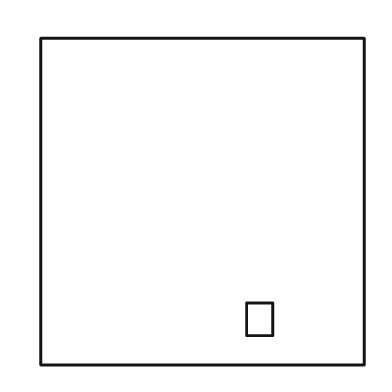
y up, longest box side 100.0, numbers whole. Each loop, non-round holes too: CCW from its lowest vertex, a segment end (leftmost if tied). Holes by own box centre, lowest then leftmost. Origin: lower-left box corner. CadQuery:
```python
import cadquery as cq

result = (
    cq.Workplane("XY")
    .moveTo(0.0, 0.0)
    .lineTo(99.0, 0.0)
    .lineTo(99.0, 100.0)
    .lineTo(0.0, 100.0)
    .close()
    .moveTo(63.0, 9.0)
    .lineTo(71.0, 9.0)
    .lineTo(71.0, 19.0)
    .lineTo(63.0, 19.0)
    .close()
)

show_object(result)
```